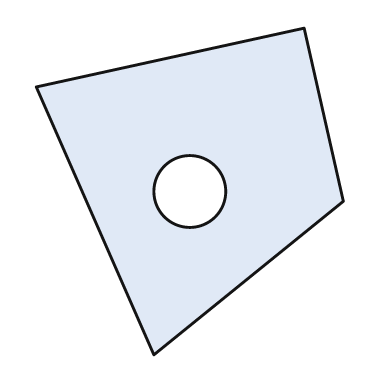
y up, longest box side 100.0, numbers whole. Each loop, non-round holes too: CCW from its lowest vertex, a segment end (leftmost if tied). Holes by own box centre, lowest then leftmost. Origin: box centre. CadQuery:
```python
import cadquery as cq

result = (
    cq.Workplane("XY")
    .moveTo(-11.0, -50.0)
    .lineTo(47.0, -3.0)
    .lineTo(35.0, 50.0)
    .lineTo(-47.0, 32.0)
    .close()
    .moveTo(0.0, 0.0)
    .circle(11.0)
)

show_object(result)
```